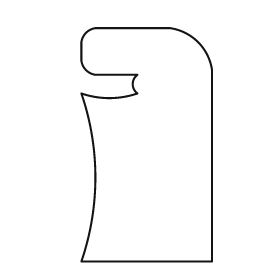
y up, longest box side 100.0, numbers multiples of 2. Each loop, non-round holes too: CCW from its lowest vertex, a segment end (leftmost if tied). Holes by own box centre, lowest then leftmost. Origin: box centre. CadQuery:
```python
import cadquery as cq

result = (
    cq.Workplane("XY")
    .moveTo(-28.0, -50.0)
    .lineTo(28.0, -50.0)
    .lineTo(28.0, 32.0)
    .threePointArc((22.0, 44.0), (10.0, 50.0))
    .lineTo(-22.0, 50.0)
    .threePointArc((-26.0, 48.0), (-28.0, 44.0))
    .lineTo(-28.0, 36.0)
    .threePointArc((-26.0, 32.0), (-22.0, 30.0))
    .lineTo(-4.0, 30.0)
    .threePointArc((-6.0, 26.0), (-4.0, 22.0))
    .threePointArc((-16.0, 20.0), (-28.0, 22.0))
    .threePointArc((-22.0, -14.0), (-28.0, -50.0))
    .close()
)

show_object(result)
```